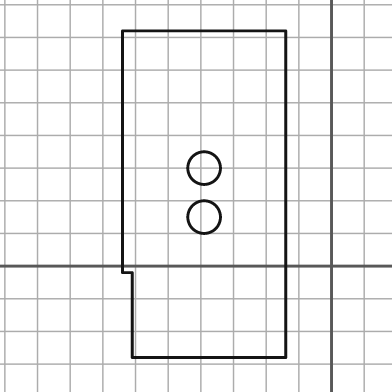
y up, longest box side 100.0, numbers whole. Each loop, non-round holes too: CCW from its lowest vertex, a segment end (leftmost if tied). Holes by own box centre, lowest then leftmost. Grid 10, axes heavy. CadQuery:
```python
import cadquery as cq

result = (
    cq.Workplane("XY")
    .moveTo(-61.0, -28.0)
    .lineTo(-14.0, -28.0)
    .lineTo(-14.0, 72.0)
    .lineTo(-64.0, 72.0)
    .lineTo(-64.0, -2.0)
    .lineTo(-61.0, -2.0)
    .close()
    .moveTo(-39.0, 15.0)
    .circle(5.0)
    .moveTo(-39.0, 30.0)
    .circle(5.0)
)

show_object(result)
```